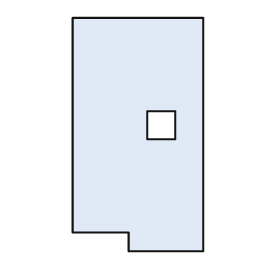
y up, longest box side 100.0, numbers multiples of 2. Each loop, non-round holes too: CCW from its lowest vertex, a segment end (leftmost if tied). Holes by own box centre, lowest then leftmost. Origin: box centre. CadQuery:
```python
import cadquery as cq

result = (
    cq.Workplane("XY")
    .moveTo(-4.0, -50.0)
    .lineTo(28.0, -50.0)
    .lineTo(28.0, 50.0)
    .lineTo(-28.0, 50.0)
    .lineTo(-28.0, -42.0)
    .lineTo(-4.0, -42.0)
    .close()
    .moveTo(4.0, -2.0)
    .lineTo(16.0, -2.0)
    .lineTo(16.0, 10.0)
    .lineTo(4.0, 10.0)
    .close()
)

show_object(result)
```